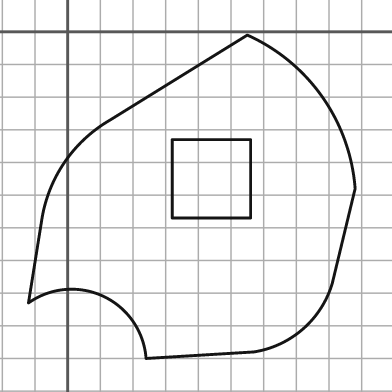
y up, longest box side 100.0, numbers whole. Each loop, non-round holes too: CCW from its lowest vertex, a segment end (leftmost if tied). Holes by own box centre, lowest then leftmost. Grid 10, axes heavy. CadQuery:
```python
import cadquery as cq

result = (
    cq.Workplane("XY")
    .moveTo(24.0, -100.0)
    .lineTo(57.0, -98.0)
    .threePointArc((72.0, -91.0), (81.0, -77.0))
    .lineTo(88.0, -48.0)
    .threePointArc((78.0, -20.0), (55.0, -1.0))
    .lineTo(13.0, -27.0)
    .threePointArc((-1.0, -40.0), (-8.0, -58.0))
    .lineTo(-12.0, -83.0)
    .threePointArc((11.0, -81.0), (24.0, -100.0))
    .close()
    .moveTo(32.0, -57.0)
    .lineTo(56.0, -57.0)
    .lineTo(56.0, -33.0)
    .lineTo(32.0, -33.0)
    .close()
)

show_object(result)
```